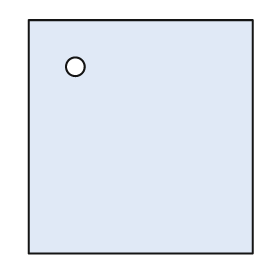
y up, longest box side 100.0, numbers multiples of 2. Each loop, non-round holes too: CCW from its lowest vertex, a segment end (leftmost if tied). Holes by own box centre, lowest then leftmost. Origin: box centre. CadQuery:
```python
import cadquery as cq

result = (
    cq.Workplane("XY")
    .moveTo(-48.0, -50.0)
    .lineTo(48.0, -50.0)
    .lineTo(48.0, 50.0)
    .lineTo(-48.0, 50.0)
    .close()
    .moveTo(-28.0, 30.0)
    .circle(4.0)
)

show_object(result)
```